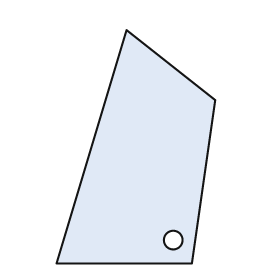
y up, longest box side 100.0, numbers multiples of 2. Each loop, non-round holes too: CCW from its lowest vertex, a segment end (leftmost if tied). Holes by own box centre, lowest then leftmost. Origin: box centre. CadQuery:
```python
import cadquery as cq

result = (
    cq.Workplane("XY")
    .moveTo(-34.0, -50.0)
    .lineTo(24.0, -50.0)
    .lineTo(34.0, 20.0)
    .lineTo(-4.0, 50.0)
    .close()
    .moveTo(16.0, -40.0)
    .circle(4.0)
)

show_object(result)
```